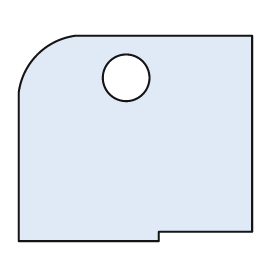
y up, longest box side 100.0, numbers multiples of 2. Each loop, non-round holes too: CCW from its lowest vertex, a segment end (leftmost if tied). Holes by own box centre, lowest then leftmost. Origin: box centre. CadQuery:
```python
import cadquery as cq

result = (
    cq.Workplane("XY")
    .moveTo(-50.0, -44.0)
    .lineTo(10.0, -44.0)
    .lineTo(10.0, -40.0)
    .lineTo(50.0, -40.0)
    .lineTo(50.0, 44.0)
    .lineTo(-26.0, 44.0)
    .threePointArc((-42.0, 36.0), (-50.0, 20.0))
    .close()
    .moveTo(-4.0, 26.0)
    .circle(10.0)
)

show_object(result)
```